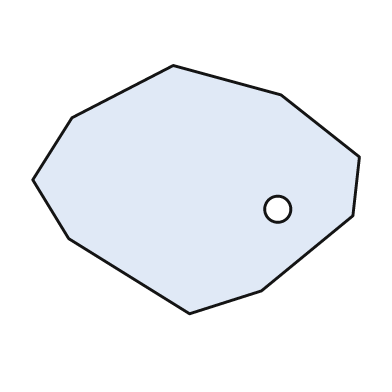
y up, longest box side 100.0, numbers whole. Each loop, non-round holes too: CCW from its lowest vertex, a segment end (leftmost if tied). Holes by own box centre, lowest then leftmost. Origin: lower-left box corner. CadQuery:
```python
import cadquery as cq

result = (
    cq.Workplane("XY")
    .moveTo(48.0, 0.0)
    .lineTo(70.0, 7.0)
    .lineTo(98.0, 30.0)
    .lineTo(100.0, 48.0)
    .lineTo(76.0, 67.0)
    .lineTo(43.0, 76.0)
    .lineTo(12.0, 60.0)
    .lineTo(0.0, 41.0)
    .lineTo(11.0, 23.0)
    .close()
    .moveTo(75.0, 32.0)
    .circle(4.0)
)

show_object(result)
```